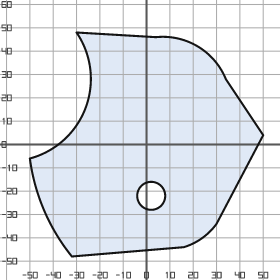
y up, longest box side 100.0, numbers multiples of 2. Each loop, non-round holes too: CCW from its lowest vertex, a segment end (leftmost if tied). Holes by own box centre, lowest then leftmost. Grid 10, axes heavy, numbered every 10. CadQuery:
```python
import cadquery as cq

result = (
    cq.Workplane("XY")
    .moveTo(-32.0, -48.0)
    .lineTo(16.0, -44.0)
    .threePointArc((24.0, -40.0), (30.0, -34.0))
    .lineTo(50.0, 4.0)
    .lineTo(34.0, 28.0)
    .threePointArc((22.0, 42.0), (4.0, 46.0))
    .lineTo(-30.0, 48.0)
    .threePointArc((-26.0, 16.0), (-50.0, -6.0))
    .threePointArc((-44.0, -28.0), (-32.0, -48.0))
    .close()
    .moveTo(2.0, -22.0)
    .circle(6.0)
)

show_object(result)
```